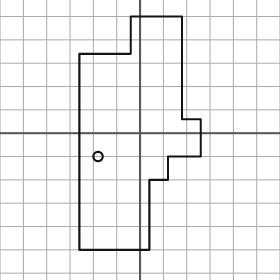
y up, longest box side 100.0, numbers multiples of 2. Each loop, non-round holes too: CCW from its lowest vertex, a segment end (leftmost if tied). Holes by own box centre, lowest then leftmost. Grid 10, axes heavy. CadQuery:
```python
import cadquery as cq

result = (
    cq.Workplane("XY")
    .moveTo(-26.0, -50.0)
    .lineTo(4.0, -50.0)
    .lineTo(4.0, -20.0)
    .lineTo(12.0, -20.0)
    .lineTo(12.0, -10.0)
    .lineTo(26.0, -10.0)
    .lineTo(26.0, 6.0)
    .lineTo(18.0, 6.0)
    .lineTo(18.0, 50.0)
    .lineTo(-4.0, 50.0)
    .lineTo(-4.0, 34.0)
    .lineTo(-26.0, 34.0)
    .close()
    .moveTo(-18.0, -10.0)
    .circle(2.0)
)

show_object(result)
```